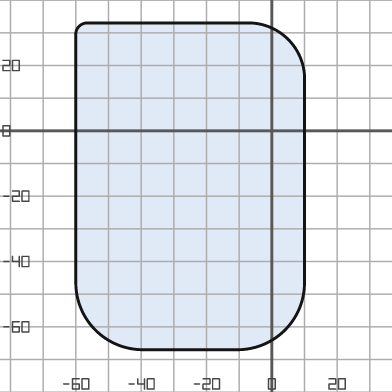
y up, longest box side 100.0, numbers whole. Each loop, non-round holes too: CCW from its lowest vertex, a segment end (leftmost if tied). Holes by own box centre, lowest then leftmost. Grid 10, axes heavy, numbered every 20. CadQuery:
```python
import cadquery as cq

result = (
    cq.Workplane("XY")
    .moveTo(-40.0, -67.0)
    .lineTo(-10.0, -67.0)
    .threePointArc((4.0, -61.0), (10.0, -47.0))
    .lineTo(10.0, 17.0)
    .threePointArc((5.0, 28.0), (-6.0, 33.0))
    .lineTo(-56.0, 33.0)
    .threePointArc((-59.0, 32.0), (-60.0, 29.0))
    .lineTo(-60.0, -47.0)
    .threePointArc((-54.0, -61.0), (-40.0, -67.0))
    .close()
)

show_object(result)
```